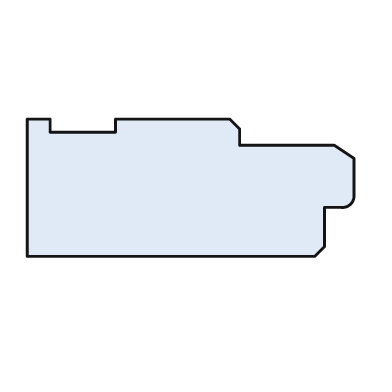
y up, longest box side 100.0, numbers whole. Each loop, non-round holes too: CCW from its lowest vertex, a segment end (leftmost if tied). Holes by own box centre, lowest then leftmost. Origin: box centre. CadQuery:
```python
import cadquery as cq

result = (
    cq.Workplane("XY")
    .moveTo(-50.0, -21.0)
    .lineTo(38.0, -21.0)
    .lineTo(41.0, -18.0)
    .lineTo(41.0, -6.0)
    .lineTo(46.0, -6.0)
    .threePointArc((49.0, -5.0), (50.0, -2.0))
    .lineTo(50.0, 9.0)
    .lineTo(44.0, 13.0)
    .lineTo(15.0, 13.0)
    .lineTo(15.0, 18.0)
    .lineTo(12.0, 21.0)
    .lineTo(-23.0, 21.0)
    .lineTo(-23.0, 17.0)
    .lineTo(-43.0, 17.0)
    .lineTo(-43.0, 21.0)
    .lineTo(-50.0, 21.0)
    .close()
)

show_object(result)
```